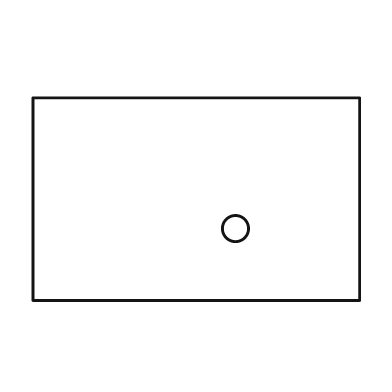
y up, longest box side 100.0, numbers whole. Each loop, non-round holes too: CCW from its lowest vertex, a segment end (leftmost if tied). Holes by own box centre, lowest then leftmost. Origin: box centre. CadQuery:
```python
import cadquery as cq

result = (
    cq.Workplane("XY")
    .moveTo(-50.0, -31.0)
    .lineTo(50.0, -31.0)
    .lineTo(50.0, 31.0)
    .lineTo(-50.0, 31.0)
    .close()
    .moveTo(12.0, -9.0)
    .circle(4.0)
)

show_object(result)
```